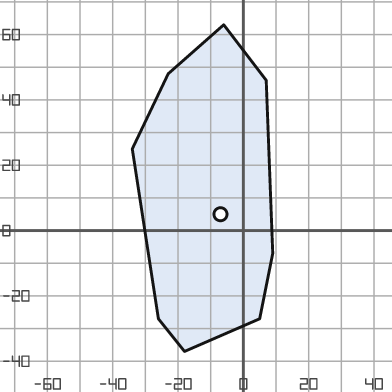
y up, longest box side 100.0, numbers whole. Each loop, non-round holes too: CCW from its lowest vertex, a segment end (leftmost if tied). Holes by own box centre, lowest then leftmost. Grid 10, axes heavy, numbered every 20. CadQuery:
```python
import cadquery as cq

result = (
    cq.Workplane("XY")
    .moveTo(-18.0, -37.0)
    .lineTo(5.0, -27.0)
    .lineTo(9.0, -7.0)
    .lineTo(7.0, 46.0)
    .lineTo(-6.0, 63.0)
    .lineTo(-23.0, 48.0)
    .lineTo(-34.0, 25.0)
    .lineTo(-26.0, -27.0)
    .close()
    .moveTo(-7.0, 5.0)
    .circle(2.0)
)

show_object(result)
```